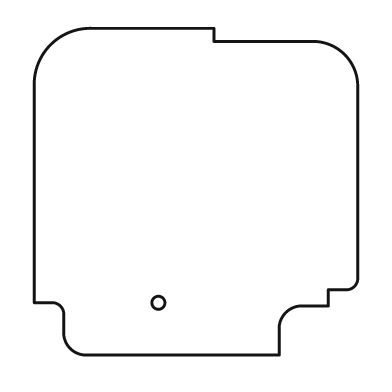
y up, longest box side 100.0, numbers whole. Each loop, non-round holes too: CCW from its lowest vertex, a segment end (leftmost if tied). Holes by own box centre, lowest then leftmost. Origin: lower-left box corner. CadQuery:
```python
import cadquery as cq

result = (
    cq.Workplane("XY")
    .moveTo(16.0, 0.0)
    .lineTo(75.0, 0.0)
    .lineTo(75.0, 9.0)
    .threePointArc((77.0, 13.0), (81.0, 15.0))
    .lineTo(90.0, 15.0)
    .lineTo(90.0, 20.0)
    .lineTo(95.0, 20.0)
    .threePointArc((98.0, 21.0), (99.0, 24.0))
    .lineTo(99.0, 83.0)
    .threePointArc((95.0, 92.0), (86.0, 96.0))
    .lineTo(55.0, 96.0)
    .lineTo(55.0, 100.0)
    .lineTo(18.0, 100.0)
    .threePointArc((5.0, 95.0), (0.0, 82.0))
    .lineTo(0.0, 16.0)
    .lineTo(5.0, 16.0)
    .threePointArc((8.0, 15.0), (9.0, 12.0))
    .lineTo(9.0, 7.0)
    .threePointArc((11.0, 2.0), (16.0, 0.0))
    .close()
    .moveTo(38.0, 16.0)
    .circle(2.0)
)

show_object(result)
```